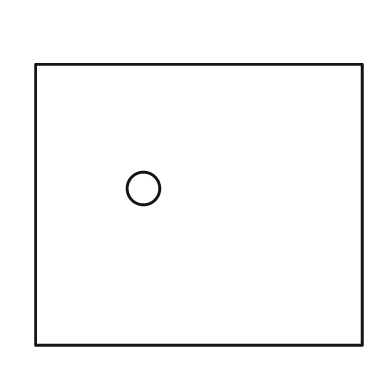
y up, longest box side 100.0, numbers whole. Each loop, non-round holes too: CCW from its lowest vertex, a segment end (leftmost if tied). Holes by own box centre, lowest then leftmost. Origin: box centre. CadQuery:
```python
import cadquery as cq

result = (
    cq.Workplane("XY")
    .moveTo(-50.0, -43.0)
    .lineTo(50.0, -43.0)
    .lineTo(50.0, 43.0)
    .lineTo(-50.0, 43.0)
    .close()
    .moveTo(-17.0, 5.0)
    .circle(5.0)
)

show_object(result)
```